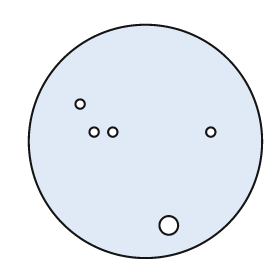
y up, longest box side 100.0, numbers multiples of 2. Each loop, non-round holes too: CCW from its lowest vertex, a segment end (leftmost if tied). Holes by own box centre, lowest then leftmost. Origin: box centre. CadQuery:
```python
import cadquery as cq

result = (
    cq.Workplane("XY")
    .moveTo(0.0, 0.0)
    .circle(50.0)
    .moveTo(10.0, -36.0)
    .circle(4.0)
    .moveTo(-22.0, 4.0)
    .circle(2.0)
    .moveTo(-14.0, 4.0)
    .circle(2.0)
    .moveTo(28.0, 4.0)
    .circle(2.0)
    .moveTo(-28.0, 16.0)
    .circle(2.0)
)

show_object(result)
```